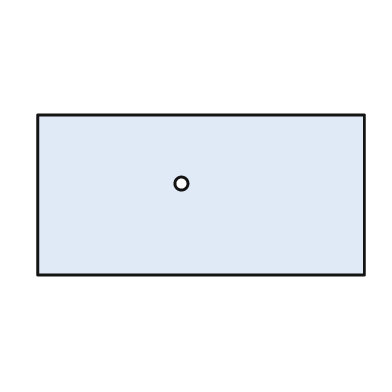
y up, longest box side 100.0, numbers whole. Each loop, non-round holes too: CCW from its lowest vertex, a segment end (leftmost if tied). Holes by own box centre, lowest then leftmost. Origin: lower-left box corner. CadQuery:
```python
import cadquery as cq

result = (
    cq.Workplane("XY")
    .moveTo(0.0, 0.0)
    .lineTo(100.0, 0.0)
    .lineTo(100.0, 49.0)
    .lineTo(0.0, 49.0)
    .close()
    .moveTo(44.0, 28.0)
    .circle(2.0)
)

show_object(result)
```